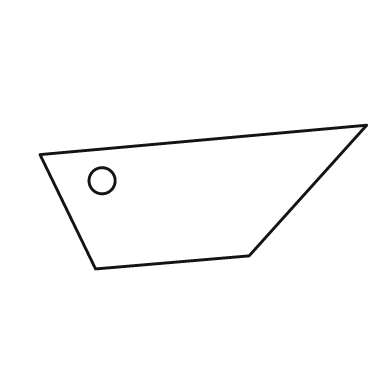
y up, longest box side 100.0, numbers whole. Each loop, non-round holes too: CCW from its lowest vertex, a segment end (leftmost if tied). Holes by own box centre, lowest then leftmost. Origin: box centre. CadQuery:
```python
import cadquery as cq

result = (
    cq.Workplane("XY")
    .moveTo(-33.0, -22.0)
    .lineTo(14.0, -18.0)
    .lineTo(50.0, 22.0)
    .lineTo(-50.0, 13.0)
    .close()
    .moveTo(-31.0, 5.0)
    .circle(4.0)
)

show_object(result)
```